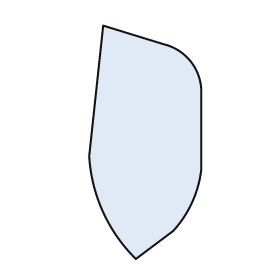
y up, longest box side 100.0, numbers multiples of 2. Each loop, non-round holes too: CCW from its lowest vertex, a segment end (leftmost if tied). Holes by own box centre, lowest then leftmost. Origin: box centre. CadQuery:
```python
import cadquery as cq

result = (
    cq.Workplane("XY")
    .moveTo(-4.0, -50.0)
    .lineTo(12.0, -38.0)
    .threePointArc((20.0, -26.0), (24.0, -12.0))
    .lineTo(24.0, 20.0)
    .threePointArc((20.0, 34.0), (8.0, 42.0))
    .lineTo(-18.0, 50.0)
    .lineTo(-24.0, -6.0)
    .threePointArc((-18.0, -30.0), (-4.0, -50.0))
    .close()
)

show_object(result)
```